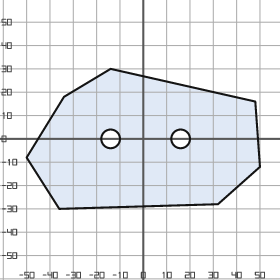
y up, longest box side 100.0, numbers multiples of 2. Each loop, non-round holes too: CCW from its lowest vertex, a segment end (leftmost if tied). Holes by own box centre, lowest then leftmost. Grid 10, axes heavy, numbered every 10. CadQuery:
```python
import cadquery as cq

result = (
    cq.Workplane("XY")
    .moveTo(-36.0, -30.0)
    .lineTo(32.0, -28.0)
    .lineTo(50.0, -12.0)
    .lineTo(48.0, 16.0)
    .lineTo(-14.0, 30.0)
    .lineTo(-34.0, 18.0)
    .lineTo(-50.0, -8.0)
    .close()
    .moveTo(-14.0, 0.0)
    .circle(4.0)
    .moveTo(16.0, 0.0)
    .circle(4.0)
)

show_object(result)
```